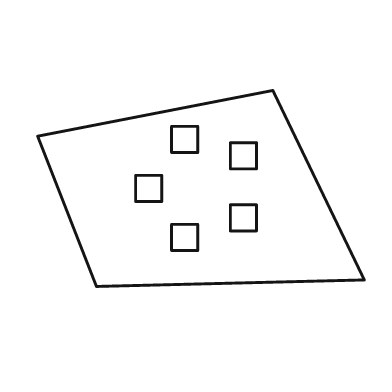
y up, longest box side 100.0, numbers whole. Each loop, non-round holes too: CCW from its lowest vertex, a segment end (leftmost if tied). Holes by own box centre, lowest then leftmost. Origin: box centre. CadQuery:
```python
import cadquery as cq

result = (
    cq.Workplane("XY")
    .moveTo(-32.0, -30.0)
    .lineTo(50.0, -28.0)
    .lineTo(22.0, 30.0)
    .lineTo(-50.0, 16.0)
    .close()
    .moveTo(-9.0, -19.0)
    .lineTo(-1.0, -19.0)
    .lineTo(-1.0, -11.0)
    .lineTo(-9.0, -11.0)
    .close()
    .moveTo(9.0, -13.0)
    .lineTo(17.0, -13.0)
    .lineTo(17.0, -5.0)
    .lineTo(9.0, -5.0)
    .close()
    .moveTo(-20.0, -4.0)
    .lineTo(-12.0, -4.0)
    .lineTo(-12.0, 4.0)
    .lineTo(-20.0, 4.0)
    .close()
    .moveTo(9.0, 6.0)
    .lineTo(17.0, 6.0)
    .lineTo(17.0, 14.0)
    .lineTo(9.0, 14.0)
    .close()
    .moveTo(-9.0, 11.0)
    .lineTo(-1.0, 11.0)
    .lineTo(-1.0, 19.0)
    .lineTo(-9.0, 19.0)
    .close()
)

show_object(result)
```